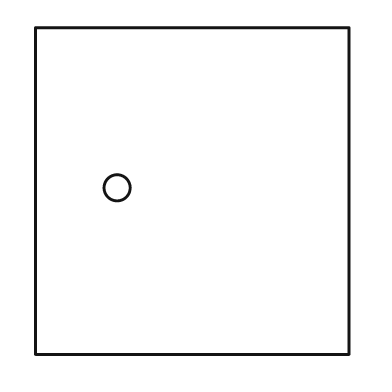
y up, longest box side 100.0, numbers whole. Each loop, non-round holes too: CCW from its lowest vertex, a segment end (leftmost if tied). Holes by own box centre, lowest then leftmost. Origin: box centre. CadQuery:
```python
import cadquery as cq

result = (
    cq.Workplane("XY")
    .moveTo(-48.0, -50.0)
    .lineTo(48.0, -50.0)
    .lineTo(48.0, 50.0)
    .lineTo(-48.0, 50.0)
    .close()
    .moveTo(-23.0, 1.0)
    .circle(4.0)
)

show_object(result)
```